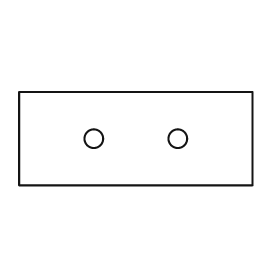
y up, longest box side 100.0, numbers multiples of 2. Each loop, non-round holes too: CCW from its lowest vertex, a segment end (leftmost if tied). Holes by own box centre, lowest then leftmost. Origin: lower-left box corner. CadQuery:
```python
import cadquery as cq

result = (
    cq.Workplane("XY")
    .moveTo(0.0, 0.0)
    .lineTo(100.0, 0.0)
    .lineTo(100.0, 40.0)
    .lineTo(0.0, 40.0)
    .close()
    .moveTo(32.0, 20.0)
    .circle(4.0)
    .moveTo(68.0, 20.0)
    .circle(4.0)
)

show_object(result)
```